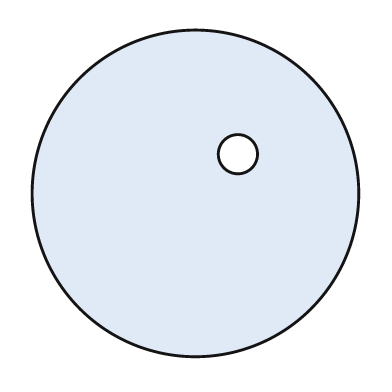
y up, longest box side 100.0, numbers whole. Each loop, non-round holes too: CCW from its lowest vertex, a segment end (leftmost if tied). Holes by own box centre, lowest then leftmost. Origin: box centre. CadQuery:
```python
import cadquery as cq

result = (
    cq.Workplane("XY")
    .moveTo(0.0, 0.0)
    .circle(50.0)
    .moveTo(13.0, 12.0)
    .circle(6.0)
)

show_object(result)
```